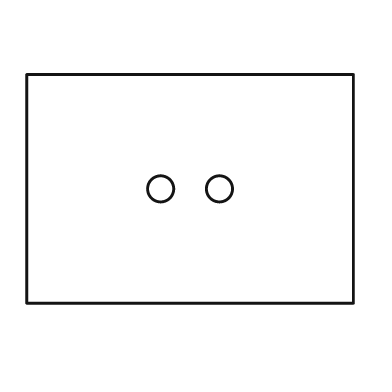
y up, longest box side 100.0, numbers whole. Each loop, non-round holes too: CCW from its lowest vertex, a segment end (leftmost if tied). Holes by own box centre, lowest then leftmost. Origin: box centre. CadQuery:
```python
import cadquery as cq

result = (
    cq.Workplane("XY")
    .moveTo(-50.0, -35.0)
    .lineTo(50.0, -35.0)
    .lineTo(50.0, 35.0)
    .lineTo(-50.0, 35.0)
    .close()
    .moveTo(-9.0, 0.0)
    .circle(4.0)
    .moveTo(9.0, 0.0)
    .circle(4.0)
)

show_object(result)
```